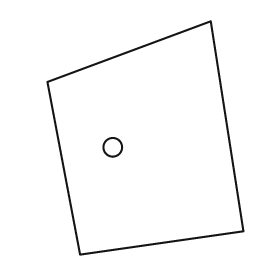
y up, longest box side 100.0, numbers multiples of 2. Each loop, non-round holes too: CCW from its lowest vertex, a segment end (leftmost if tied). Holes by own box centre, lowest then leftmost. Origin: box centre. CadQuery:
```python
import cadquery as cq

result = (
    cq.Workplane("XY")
    .moveTo(-28.0, -50.0)
    .lineTo(42.0, -40.0)
    .lineTo(28.0, 50.0)
    .lineTo(-42.0, 24.0)
    .close()
    .moveTo(-14.0, -4.0)
    .circle(4.0)
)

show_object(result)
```